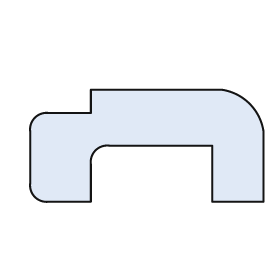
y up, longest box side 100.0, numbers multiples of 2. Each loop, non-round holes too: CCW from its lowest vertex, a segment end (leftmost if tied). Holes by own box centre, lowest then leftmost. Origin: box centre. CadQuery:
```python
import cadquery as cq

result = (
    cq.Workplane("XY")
    .moveTo(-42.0, -24.0)
    .lineTo(-24.0, -24.0)
    .lineTo(-24.0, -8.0)
    .threePointArc((-22.0, -2.0), (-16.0, 0.0))
    .lineTo(28.0, 0.0)
    .lineTo(28.0, -24.0)
    .lineTo(50.0, -24.0)
    .lineTo(50.0, 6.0)
    .threePointArc((44.0, 18.0), (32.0, 24.0))
    .lineTo(-24.0, 24.0)
    .lineTo(-24.0, 14.0)
    .lineTo(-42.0, 14.0)
    .threePointArc((-48.0, 12.0), (-50.0, 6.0))
    .lineTo(-50.0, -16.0)
    .threePointArc((-48.0, -22.0), (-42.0, -24.0))
    .close()
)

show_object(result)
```